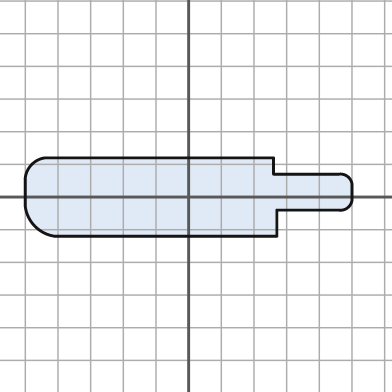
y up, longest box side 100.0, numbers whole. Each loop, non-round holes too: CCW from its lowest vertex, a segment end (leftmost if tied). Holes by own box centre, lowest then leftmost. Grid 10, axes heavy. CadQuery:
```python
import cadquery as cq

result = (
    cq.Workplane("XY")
    .moveTo(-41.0, -12.0)
    .lineTo(27.0, -12.0)
    .lineTo(27.0, -4.0)
    .lineTo(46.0, -4.0)
    .threePointArc((49.0, -3.0), (50.0, 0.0))
    .lineTo(50.0, 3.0)
    .threePointArc((49.0, 6.0), (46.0, 7.0))
    .lineTo(26.0, 7.0)
    .lineTo(26.0, 12.0)
    .lineTo(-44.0, 12.0)
    .threePointArc((-48.0, 10.0), (-50.0, 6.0))
    .lineTo(-50.0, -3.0)
    .threePointArc((-47.0, -9.0), (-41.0, -12.0))
    .close()
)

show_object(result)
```